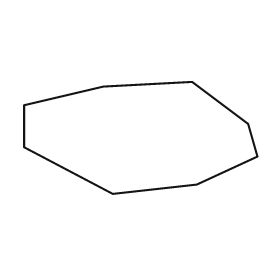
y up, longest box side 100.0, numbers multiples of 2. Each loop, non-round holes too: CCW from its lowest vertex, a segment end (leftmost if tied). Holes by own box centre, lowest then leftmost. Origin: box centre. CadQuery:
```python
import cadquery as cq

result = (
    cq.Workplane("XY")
    .moveTo(-12.0, -24.0)
    .lineTo(24.0, -20.0)
    .lineTo(50.0, -8.0)
    .lineTo(46.0, 6.0)
    .lineTo(22.0, 24.0)
    .lineTo(-16.0, 22.0)
    .lineTo(-50.0, 14.0)
    .lineTo(-50.0, -4.0)
    .close()
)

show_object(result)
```